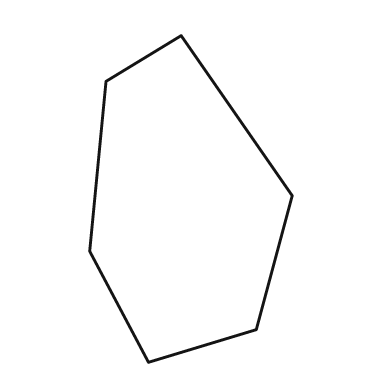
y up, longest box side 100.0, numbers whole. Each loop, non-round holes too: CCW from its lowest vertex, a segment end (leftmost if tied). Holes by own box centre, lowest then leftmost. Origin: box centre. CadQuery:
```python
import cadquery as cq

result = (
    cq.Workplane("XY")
    .moveTo(-13.0, -50.0)
    .lineTo(20.0, -40.0)
    .lineTo(31.0, 1.0)
    .lineTo(-3.0, 50.0)
    .lineTo(-26.0, 36.0)
    .lineTo(-31.0, -16.0)
    .close()
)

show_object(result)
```